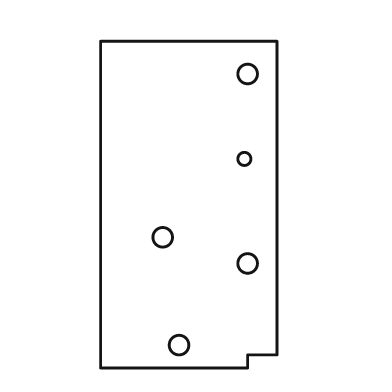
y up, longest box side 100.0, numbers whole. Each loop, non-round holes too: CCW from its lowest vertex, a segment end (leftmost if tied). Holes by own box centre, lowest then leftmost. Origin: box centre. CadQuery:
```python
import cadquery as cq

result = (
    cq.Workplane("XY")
    .moveTo(-27.0, -50.0)
    .lineTo(18.0, -50.0)
    .lineTo(18.0, -46.0)
    .lineTo(27.0, -46.0)
    .lineTo(27.0, 50.0)
    .lineTo(-27.0, 50.0)
    .close()
    .moveTo(-3.0, -43.0)
    .circle(3.0)
    .moveTo(18.0, -18.0)
    .circle(3.0)
    .moveTo(-8.0, -10.0)
    .circle(3.0)
    .moveTo(17.0, 14.0)
    .circle(2.0)
    .moveTo(18.0, 40.0)
    .circle(3.0)
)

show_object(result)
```